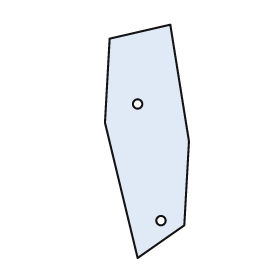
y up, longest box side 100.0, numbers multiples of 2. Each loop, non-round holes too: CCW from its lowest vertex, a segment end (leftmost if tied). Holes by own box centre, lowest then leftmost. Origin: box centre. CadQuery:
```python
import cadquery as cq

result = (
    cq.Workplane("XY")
    .moveTo(-4.0, -50.0)
    .lineTo(16.0, -36.0)
    .lineTo(18.0, 0.0)
    .lineTo(10.0, 50.0)
    .lineTo(-16.0, 44.0)
    .lineTo(-18.0, 8.0)
    .close()
    .moveTo(6.0, -34.0)
    .circle(2.0)
    .moveTo(-4.0, 16.0)
    .circle(2.0)
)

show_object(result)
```